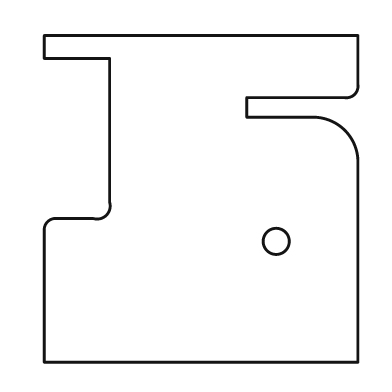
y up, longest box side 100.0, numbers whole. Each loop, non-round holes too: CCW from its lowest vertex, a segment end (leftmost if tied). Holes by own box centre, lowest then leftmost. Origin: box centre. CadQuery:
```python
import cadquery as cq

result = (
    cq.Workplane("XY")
    .moveTo(-48.0, -50.0)
    .lineTo(48.0, -50.0)
    .lineTo(48.0, 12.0)
    .threePointArc((44.0, 21.0), (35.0, 25.0))
    .lineTo(14.0, 25.0)
    .lineTo(14.0, 31.0)
    .lineTo(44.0, 31.0)
    .threePointArc((47.0, 32.0), (48.0, 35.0))
    .lineTo(48.0, 50.0)
    .lineTo(-48.0, 50.0)
    .lineTo(-48.0, 43.0)
    .lineTo(-28.0, 43.0)
    .lineTo(-28.0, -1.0)
    .threePointArc((-29.0, -5.0), (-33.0, -6.0))
    .lineTo(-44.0, -6.0)
    .threePointArc((-47.0, -7.0), (-48.0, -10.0))
    .close()
    .moveTo(23.0, -13.0)
    .circle(4.0)
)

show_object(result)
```